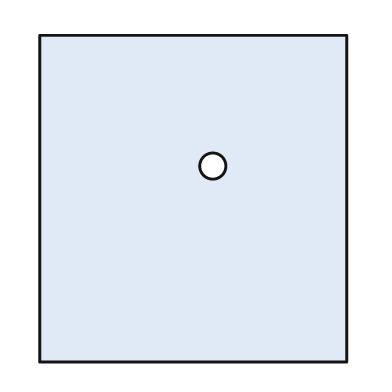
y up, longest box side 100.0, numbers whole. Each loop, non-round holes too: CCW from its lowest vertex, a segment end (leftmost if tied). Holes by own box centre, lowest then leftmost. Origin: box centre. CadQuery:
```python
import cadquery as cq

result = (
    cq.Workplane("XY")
    .moveTo(-47.0, -50.0)
    .lineTo(47.0, -50.0)
    .lineTo(47.0, 50.0)
    .lineTo(-47.0, 50.0)
    .close()
    .moveTo(6.0, 10.0)
    .circle(4.0)
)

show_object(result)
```